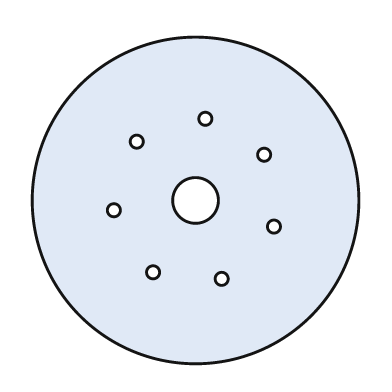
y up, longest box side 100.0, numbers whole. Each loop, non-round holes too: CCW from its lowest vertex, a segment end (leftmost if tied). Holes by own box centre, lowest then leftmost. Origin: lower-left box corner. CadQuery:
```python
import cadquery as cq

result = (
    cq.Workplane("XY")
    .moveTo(50.0, 50.0)
    .circle(50.0)
    .moveTo(58.0, 26.0)
    .circle(2.0)
    .moveTo(37.0, 28.0)
    .circle(2.0)
    .moveTo(74.0, 42.0)
    .circle(2.0)
    .moveTo(25.0, 47.0)
    .circle(2.0)
    .moveTo(50.0, 50.0)
    .circle(7.0)
    .moveTo(71.0, 64.0)
    .circle(2.0)
    .moveTo(32.0, 68.0)
    .circle(2.0)
    .moveTo(53.0, 75.0)
    .circle(2.0)
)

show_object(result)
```